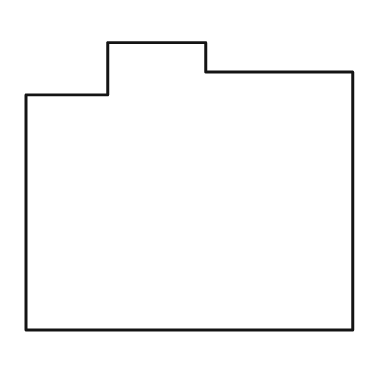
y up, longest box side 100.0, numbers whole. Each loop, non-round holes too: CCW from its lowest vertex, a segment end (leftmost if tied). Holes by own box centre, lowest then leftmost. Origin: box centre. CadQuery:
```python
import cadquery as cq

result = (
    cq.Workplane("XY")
    .moveTo(-50.0, -44.0)
    .lineTo(50.0, -44.0)
    .lineTo(50.0, 35.0)
    .lineTo(5.0, 35.0)
    .lineTo(5.0, 44.0)
    .lineTo(-25.0, 44.0)
    .lineTo(-25.0, 28.0)
    .lineTo(-50.0, 28.0)
    .close()
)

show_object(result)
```